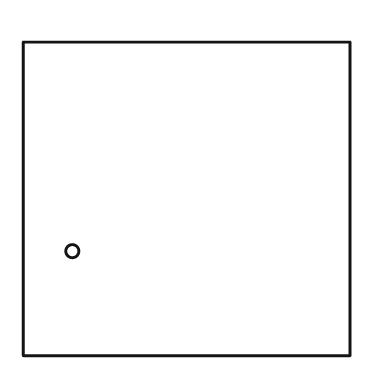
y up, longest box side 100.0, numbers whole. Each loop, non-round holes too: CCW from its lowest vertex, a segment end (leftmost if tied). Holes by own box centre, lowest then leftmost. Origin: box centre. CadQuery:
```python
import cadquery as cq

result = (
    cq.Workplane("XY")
    .moveTo(-50.0, -48.0)
    .lineTo(50.0, -48.0)
    .lineTo(50.0, 48.0)
    .lineTo(-50.0, 48.0)
    .close()
    .moveTo(-35.0, -16.0)
    .circle(2.0)
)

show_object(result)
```